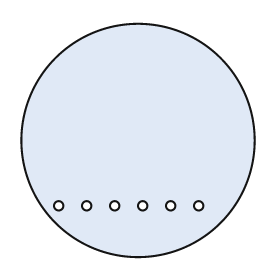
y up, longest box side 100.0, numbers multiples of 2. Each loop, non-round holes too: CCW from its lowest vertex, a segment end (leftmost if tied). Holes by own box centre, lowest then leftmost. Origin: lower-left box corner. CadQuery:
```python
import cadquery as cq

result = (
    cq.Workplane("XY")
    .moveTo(50.0, 50.0)
    .circle(50.0)
    .moveTo(16.0, 22.0)
    .circle(2.0)
    .moveTo(28.0, 22.0)
    .circle(2.0)
    .moveTo(40.0, 22.0)
    .circle(2.0)
    .moveTo(52.0, 22.0)
    .circle(2.0)
    .moveTo(64.0, 22.0)
    .circle(2.0)
    .moveTo(76.0, 22.0)
    .circle(2.0)
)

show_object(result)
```